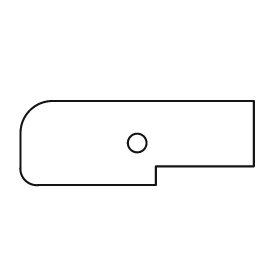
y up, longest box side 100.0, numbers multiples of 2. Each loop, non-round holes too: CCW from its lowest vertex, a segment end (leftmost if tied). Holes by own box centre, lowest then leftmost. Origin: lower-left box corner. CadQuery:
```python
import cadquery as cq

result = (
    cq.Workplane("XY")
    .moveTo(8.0, 0.0)
    .lineTo(58.0, 0.0)
    .lineTo(58.0, 8.0)
    .lineTo(100.0, 8.0)
    .lineTo(100.0, 36.0)
    .lineTo(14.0, 36.0)
    .threePointArc((4.0, 32.0), (0.0, 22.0))
    .lineTo(0.0, 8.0)
    .threePointArc((2.0, 2.0), (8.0, 0.0))
    .close()
    .moveTo(50.0, 18.0)
    .circle(4.0)
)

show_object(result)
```